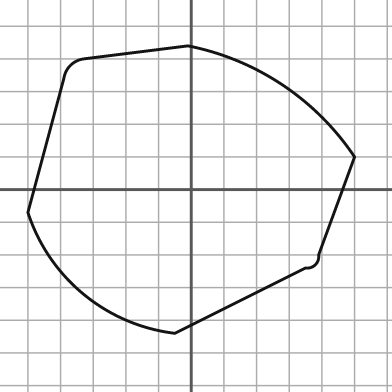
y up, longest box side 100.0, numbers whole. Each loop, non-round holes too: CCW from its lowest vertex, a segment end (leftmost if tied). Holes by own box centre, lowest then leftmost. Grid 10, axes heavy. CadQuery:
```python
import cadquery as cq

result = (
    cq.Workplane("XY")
    .moveTo(-5.0, -44.0)
    .lineTo(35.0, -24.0)
    .threePointArc((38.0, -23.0), (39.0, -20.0))
    .lineTo(50.0, 10.0)
    .threePointArc((28.0, 32.0), (-1.0, 44.0))
    .lineTo(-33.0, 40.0)
    .threePointArc((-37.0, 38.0), (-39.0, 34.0))
    .lineTo(-50.0, -7.0)
    .threePointArc((-33.0, -32.0), (-5.0, -44.0))
    .close()
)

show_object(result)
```